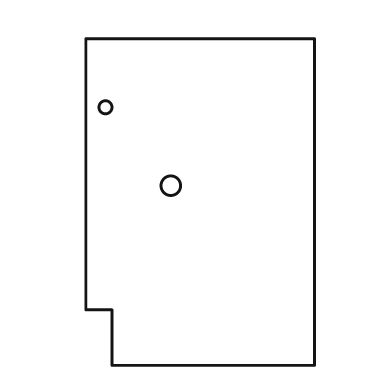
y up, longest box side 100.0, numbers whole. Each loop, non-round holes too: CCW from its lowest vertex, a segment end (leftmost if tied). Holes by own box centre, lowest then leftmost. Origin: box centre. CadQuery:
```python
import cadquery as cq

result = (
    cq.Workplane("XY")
    .moveTo(-27.0, -50.0)
    .lineTo(35.0, -50.0)
    .lineTo(35.0, 50.0)
    .lineTo(-35.0, 50.0)
    .lineTo(-35.0, -33.0)
    .lineTo(-27.0, -33.0)
    .close()
    .moveTo(-9.0, 5.0)
    .circle(3.0)
    .moveTo(-29.0, 29.0)
    .circle(2.0)
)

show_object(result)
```